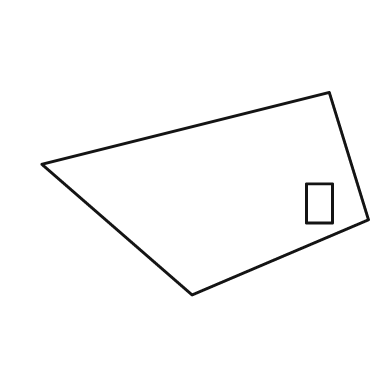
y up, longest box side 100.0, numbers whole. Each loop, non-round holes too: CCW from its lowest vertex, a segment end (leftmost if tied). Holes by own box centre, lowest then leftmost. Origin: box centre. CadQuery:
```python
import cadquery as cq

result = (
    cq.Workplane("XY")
    .moveTo(-4.0, -31.0)
    .lineTo(50.0, -8.0)
    .lineTo(38.0, 31.0)
    .lineTo(-50.0, 9.0)
    .close()
    .moveTo(31.0, -9.0)
    .lineTo(39.0, -9.0)
    .lineTo(39.0, 3.0)
    .lineTo(31.0, 3.0)
    .close()
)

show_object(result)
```